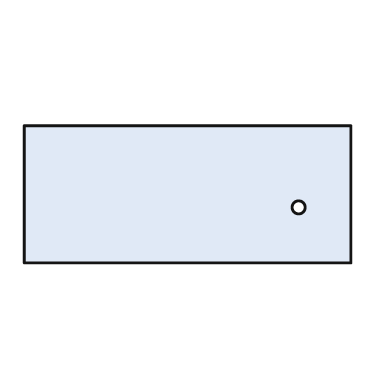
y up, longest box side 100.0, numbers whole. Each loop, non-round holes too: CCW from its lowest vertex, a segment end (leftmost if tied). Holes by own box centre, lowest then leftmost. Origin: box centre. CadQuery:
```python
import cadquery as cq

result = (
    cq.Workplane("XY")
    .moveTo(-50.0, -21.0)
    .lineTo(50.0, -21.0)
    .lineTo(50.0, 21.0)
    .lineTo(-50.0, 21.0)
    .close()
    .moveTo(34.0, -4.0)
    .circle(2.0)
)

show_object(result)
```